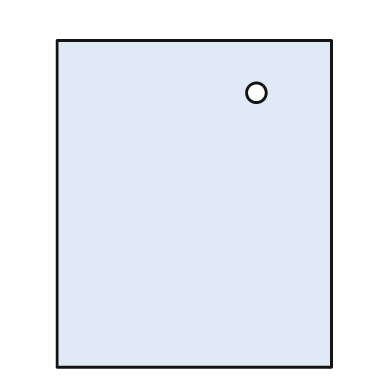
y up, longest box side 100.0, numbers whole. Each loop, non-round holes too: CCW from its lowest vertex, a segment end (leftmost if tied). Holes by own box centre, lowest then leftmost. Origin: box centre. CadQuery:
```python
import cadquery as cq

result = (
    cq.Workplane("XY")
    .moveTo(-42.0, -50.0)
    .lineTo(42.0, -50.0)
    .lineTo(42.0, 50.0)
    .lineTo(-42.0, 50.0)
    .close()
    .moveTo(19.0, 34.0)
    .circle(3.0)
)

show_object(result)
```